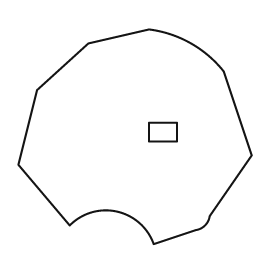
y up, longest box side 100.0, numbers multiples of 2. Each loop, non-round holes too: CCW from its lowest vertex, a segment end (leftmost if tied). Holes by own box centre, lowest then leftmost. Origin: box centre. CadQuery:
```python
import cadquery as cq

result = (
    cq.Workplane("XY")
    .moveTo(8.0, -46.0)
    .lineTo(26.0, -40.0)
    .threePointArc((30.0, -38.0), (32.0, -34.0))
    .lineTo(50.0, -8.0)
    .lineTo(38.0, 28.0)
    .threePointArc((24.0, 40.0), (6.0, 46.0))
    .lineTo(-20.0, 40.0)
    .lineTo(-42.0, 20.0)
    .lineTo(-50.0, -12.0)
    .lineTo(-28.0, -38.0)
    .threePointArc((-8.0, -32.0), (8.0, -46.0))
    .close()
    .moveTo(6.0, -2.0)
    .lineTo(18.0, -2.0)
    .lineTo(18.0, 6.0)
    .lineTo(6.0, 6.0)
    .close()
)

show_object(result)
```